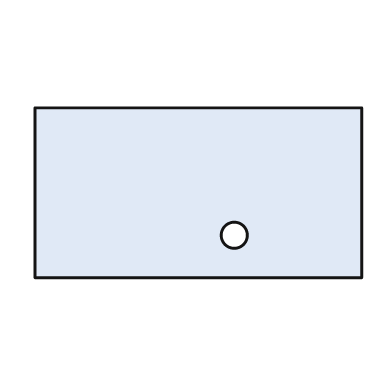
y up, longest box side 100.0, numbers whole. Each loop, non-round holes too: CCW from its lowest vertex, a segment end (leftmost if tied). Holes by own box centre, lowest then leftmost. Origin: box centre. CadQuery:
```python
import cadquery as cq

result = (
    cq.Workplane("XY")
    .moveTo(-50.0, -26.0)
    .lineTo(50.0, -26.0)
    .lineTo(50.0, 26.0)
    .lineTo(-50.0, 26.0)
    .close()
    .moveTo(11.0, -13.0)
    .circle(4.0)
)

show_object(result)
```